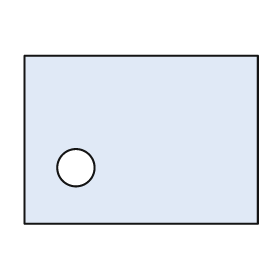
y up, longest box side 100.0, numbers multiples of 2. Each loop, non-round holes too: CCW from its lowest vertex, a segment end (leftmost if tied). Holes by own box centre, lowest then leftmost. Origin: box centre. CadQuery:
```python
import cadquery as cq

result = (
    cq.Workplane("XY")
    .moveTo(-50.0, -36.0)
    .lineTo(50.0, -36.0)
    .lineTo(50.0, 36.0)
    .lineTo(-50.0, 36.0)
    .close()
    .moveTo(-28.0, -12.0)
    .circle(8.0)
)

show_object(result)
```